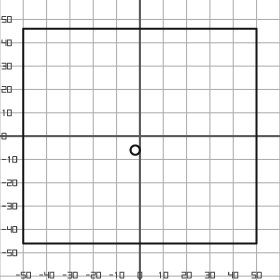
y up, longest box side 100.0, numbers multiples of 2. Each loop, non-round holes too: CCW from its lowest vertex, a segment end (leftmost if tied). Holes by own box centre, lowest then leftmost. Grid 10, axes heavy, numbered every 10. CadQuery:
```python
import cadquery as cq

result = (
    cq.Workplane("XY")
    .moveTo(-50.0, -46.0)
    .lineTo(50.0, -46.0)
    .lineTo(50.0, 46.0)
    .lineTo(-50.0, 46.0)
    .close()
    .moveTo(-2.0, -6.0)
    .circle(2.0)
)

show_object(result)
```